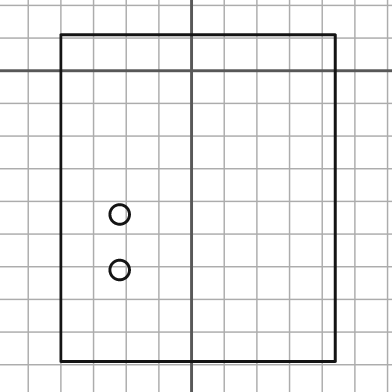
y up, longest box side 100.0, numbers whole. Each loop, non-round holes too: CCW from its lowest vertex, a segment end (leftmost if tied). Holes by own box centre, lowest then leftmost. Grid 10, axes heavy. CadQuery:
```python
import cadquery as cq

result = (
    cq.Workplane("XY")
    .moveTo(-40.0, -89.0)
    .lineTo(44.0, -89.0)
    .lineTo(44.0, 11.0)
    .lineTo(-40.0, 11.0)
    .close()
    .moveTo(-22.0, -61.0)
    .circle(3.0)
    .moveTo(-22.0, -44.0)
    .circle(3.0)
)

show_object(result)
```